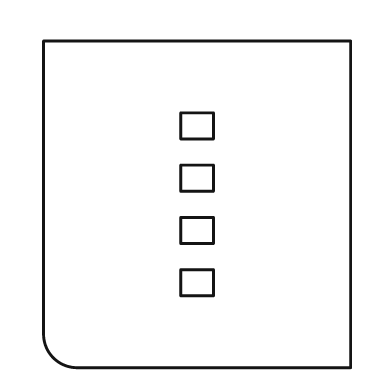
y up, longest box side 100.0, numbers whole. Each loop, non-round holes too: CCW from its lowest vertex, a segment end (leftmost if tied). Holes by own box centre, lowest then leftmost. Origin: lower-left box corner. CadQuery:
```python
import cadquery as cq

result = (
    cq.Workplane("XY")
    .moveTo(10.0, 0.0)
    .lineTo(94.0, 0.0)
    .lineTo(94.0, 100.0)
    .lineTo(0.0, 100.0)
    .lineTo(0.0, 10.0)
    .threePointArc((3.0, 3.0), (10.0, 0.0))
    .close()
    .moveTo(42.0, 22.0)
    .lineTo(52.0, 22.0)
    .lineTo(52.0, 30.0)
    .lineTo(42.0, 30.0)
    .close()
    .moveTo(42.0, 38.0)
    .lineTo(52.0, 38.0)
    .lineTo(52.0, 46.0)
    .lineTo(42.0, 46.0)
    .close()
    .moveTo(42.0, 54.0)
    .lineTo(52.0, 54.0)
    .lineTo(52.0, 62.0)
    .lineTo(42.0, 62.0)
    .close()
    .moveTo(42.0, 70.0)
    .lineTo(52.0, 70.0)
    .lineTo(52.0, 78.0)
    .lineTo(42.0, 78.0)
    .close()
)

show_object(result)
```